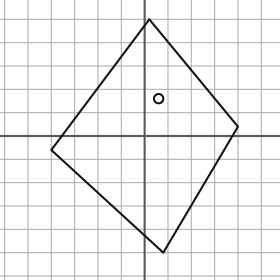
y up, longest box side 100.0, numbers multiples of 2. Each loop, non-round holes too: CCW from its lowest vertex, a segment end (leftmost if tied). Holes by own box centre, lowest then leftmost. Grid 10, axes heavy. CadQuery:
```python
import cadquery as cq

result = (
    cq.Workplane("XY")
    .moveTo(8.0, -50.0)
    .lineTo(40.0, 4.0)
    .lineTo(2.0, 50.0)
    .lineTo(-40.0, -6.0)
    .close()
    .moveTo(6.0, 16.0)
    .circle(2.0)
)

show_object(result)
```